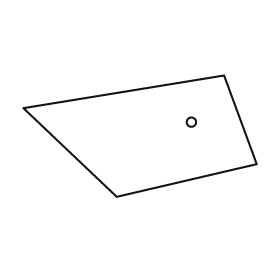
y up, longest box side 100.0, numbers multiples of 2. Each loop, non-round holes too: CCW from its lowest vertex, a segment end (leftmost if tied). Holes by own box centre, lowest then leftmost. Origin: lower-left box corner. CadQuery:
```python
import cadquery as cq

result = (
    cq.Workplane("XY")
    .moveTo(40.0, 0.0)
    .lineTo(100.0, 14.0)
    .lineTo(86.0, 52.0)
    .lineTo(0.0, 38.0)
    .close()
    .moveTo(72.0, 32.0)
    .circle(2.0)
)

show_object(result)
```